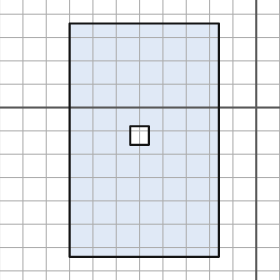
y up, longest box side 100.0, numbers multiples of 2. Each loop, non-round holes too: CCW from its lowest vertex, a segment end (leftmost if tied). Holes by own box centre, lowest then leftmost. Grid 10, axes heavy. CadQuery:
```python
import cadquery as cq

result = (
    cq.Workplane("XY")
    .moveTo(-80.0, -64.0)
    .lineTo(-16.0, -64.0)
    .lineTo(-16.0, 36.0)
    .lineTo(-80.0, 36.0)
    .close()
    .moveTo(-54.0, -16.0)
    .lineTo(-46.0, -16.0)
    .lineTo(-46.0, -8.0)
    .lineTo(-54.0, -8.0)
    .close()
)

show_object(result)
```